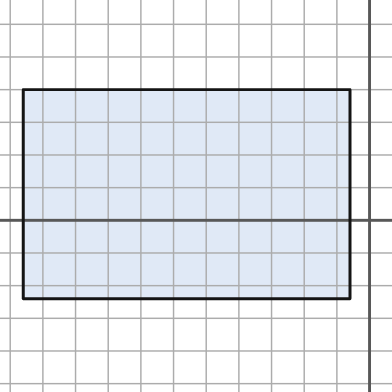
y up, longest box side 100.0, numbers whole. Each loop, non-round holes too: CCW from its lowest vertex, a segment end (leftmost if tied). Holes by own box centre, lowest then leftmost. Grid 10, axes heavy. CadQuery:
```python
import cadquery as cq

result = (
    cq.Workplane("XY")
    .moveTo(-106.0, -24.0)
    .lineTo(-6.0, -24.0)
    .lineTo(-6.0, 40.0)
    .lineTo(-106.0, 40.0)
    .close()
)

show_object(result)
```